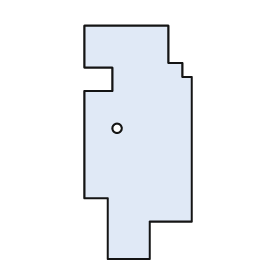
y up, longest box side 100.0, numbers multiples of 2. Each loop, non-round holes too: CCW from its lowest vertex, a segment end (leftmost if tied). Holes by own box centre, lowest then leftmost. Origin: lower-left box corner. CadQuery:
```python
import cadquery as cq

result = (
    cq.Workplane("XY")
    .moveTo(10.0, 0.0)
    .lineTo(28.0, 0.0)
    .lineTo(28.0, 16.0)
    .lineTo(46.0, 16.0)
    .lineTo(46.0, 78.0)
    .lineTo(42.0, 78.0)
    .lineTo(42.0, 84.0)
    .lineTo(36.0, 84.0)
    .lineTo(36.0, 100.0)
    .lineTo(0.0, 100.0)
    .lineTo(0.0, 82.0)
    .lineTo(12.0, 82.0)
    .lineTo(12.0, 72.0)
    .lineTo(0.0, 72.0)
    .lineTo(0.0, 26.0)
    .lineTo(10.0, 26.0)
    .close()
    .moveTo(14.0, 56.0)
    .circle(2.0)
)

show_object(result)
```